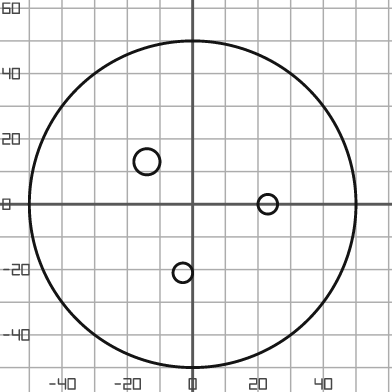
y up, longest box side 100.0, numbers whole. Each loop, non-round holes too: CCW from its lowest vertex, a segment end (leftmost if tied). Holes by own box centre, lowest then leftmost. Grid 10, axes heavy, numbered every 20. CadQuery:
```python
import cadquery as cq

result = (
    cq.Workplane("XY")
    .moveTo(0.0, 0.0)
    .circle(50.0)
    .moveTo(-3.0, -21.0)
    .circle(3.0)
    .moveTo(23.0, 0.0)
    .circle(3.0)
    .moveTo(-14.0, 13.0)
    .circle(4.0)
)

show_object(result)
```